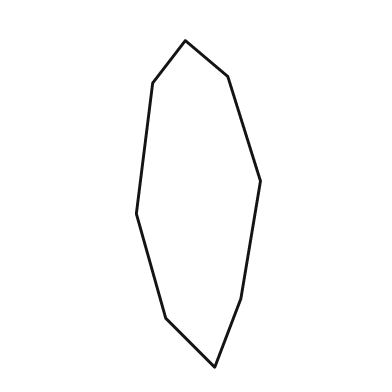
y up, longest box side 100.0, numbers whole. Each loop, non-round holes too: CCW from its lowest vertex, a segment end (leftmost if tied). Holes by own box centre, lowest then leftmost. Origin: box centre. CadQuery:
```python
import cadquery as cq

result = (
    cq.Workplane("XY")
    .moveTo(5.0, -50.0)
    .lineTo(13.0, -29.0)
    .lineTo(19.0, 7.0)
    .lineTo(9.0, 39.0)
    .lineTo(-4.0, 50.0)
    .lineTo(-14.0, 37.0)
    .lineTo(-19.0, -3.0)
    .lineTo(-10.0, -35.0)
    .close()
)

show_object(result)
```